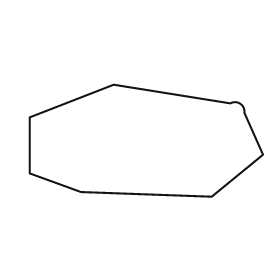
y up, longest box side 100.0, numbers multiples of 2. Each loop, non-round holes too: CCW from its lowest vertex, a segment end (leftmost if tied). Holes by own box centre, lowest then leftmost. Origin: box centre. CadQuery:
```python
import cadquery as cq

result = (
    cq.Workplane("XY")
    .moveTo(28.0, -24.0)
    .lineTo(50.0, -6.0)
    .lineTo(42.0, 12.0)
    .threePointArc((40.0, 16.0), (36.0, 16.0))
    .lineTo(-14.0, 24.0)
    .lineTo(-50.0, 10.0)
    .lineTo(-50.0, -14.0)
    .lineTo(-28.0, -22.0)
    .close()
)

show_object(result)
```